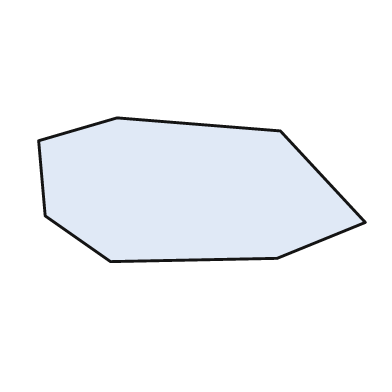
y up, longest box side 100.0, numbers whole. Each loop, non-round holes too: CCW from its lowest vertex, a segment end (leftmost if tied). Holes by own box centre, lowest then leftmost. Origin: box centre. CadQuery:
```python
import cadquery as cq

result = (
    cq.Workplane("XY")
    .moveTo(-28.0, -22.0)
    .lineTo(23.0, -21.0)
    .lineTo(50.0, -10.0)
    .lineTo(24.0, 18.0)
    .lineTo(-26.0, 22.0)
    .lineTo(-50.0, 15.0)
    .lineTo(-48.0, -8.0)
    .close()
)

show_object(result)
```